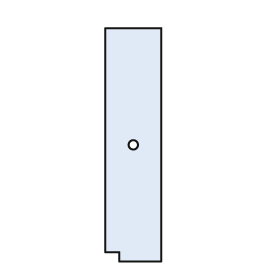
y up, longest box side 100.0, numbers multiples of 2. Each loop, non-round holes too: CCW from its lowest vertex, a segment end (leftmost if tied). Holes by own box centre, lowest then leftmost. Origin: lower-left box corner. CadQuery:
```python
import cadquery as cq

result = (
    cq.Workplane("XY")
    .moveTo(6.0, 0.0)
    .lineTo(24.0, 0.0)
    .lineTo(24.0, 100.0)
    .lineTo(0.0, 100.0)
    .lineTo(0.0, 4.0)
    .lineTo(6.0, 4.0)
    .close()
    .moveTo(12.0, 50.0)
    .circle(2.0)
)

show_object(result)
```